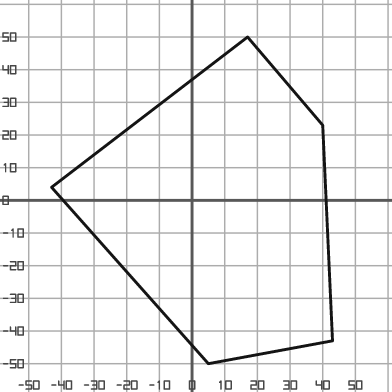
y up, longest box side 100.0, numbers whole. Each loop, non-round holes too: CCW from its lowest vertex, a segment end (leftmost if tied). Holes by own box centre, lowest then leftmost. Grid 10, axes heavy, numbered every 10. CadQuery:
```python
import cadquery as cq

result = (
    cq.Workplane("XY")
    .moveTo(5.0, -50.0)
    .lineTo(43.0, -43.0)
    .lineTo(40.0, 23.0)
    .lineTo(17.0, 50.0)
    .lineTo(-43.0, 4.0)
    .close()
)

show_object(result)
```